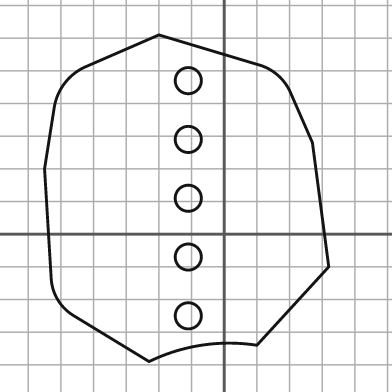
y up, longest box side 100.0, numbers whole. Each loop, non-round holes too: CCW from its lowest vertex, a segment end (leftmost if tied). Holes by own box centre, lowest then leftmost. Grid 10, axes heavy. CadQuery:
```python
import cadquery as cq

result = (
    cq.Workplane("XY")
    .moveTo(-23.0, -39.0)
    .threePointArc((-7.0, -34.0), (10.0, -34.0))
    .lineTo(32.0, -10.0)
    .lineTo(27.0, 28.0)
    .lineTo(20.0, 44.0)
    .threePointArc((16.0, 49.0), (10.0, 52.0))
    .lineTo(-20.0, 61.0)
    .lineTo(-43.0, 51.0)
    .threePointArc((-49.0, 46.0), (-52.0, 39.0))
    .lineTo(-55.0, 20.0)
    .lineTo(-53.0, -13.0)
    .threePointArc((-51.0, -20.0), (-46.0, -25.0))
    .close()
    .moveTo(-11.0, -25.0)
    .circle(4.0)
    .moveTo(-11.0, -7.0)
    .circle(4.0)
    .moveTo(-11.0, 11.0)
    .circle(4.0)
    .moveTo(-11.0, 29.0)
    .circle(4.0)
    .moveTo(-11.0, 47.0)
    .circle(4.0)
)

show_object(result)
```